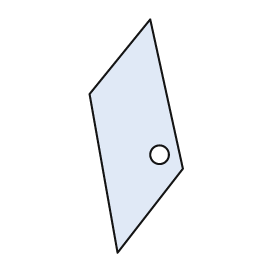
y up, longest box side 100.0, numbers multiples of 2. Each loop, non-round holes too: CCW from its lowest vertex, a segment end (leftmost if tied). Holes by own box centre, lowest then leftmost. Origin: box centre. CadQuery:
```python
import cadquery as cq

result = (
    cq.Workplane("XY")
    .moveTo(-8.0, -50.0)
    .lineTo(20.0, -14.0)
    .lineTo(6.0, 50.0)
    .lineTo(-20.0, 18.0)
    .close()
    .moveTo(10.0, -8.0)
    .circle(4.0)
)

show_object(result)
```